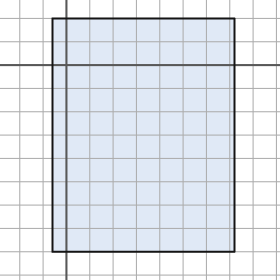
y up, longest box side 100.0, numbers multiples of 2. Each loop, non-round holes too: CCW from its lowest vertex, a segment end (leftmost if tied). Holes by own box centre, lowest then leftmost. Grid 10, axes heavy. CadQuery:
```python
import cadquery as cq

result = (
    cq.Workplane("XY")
    .moveTo(-6.0, -80.0)
    .lineTo(72.0, -80.0)
    .lineTo(72.0, 20.0)
    .lineTo(-6.0, 20.0)
    .close()
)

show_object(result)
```